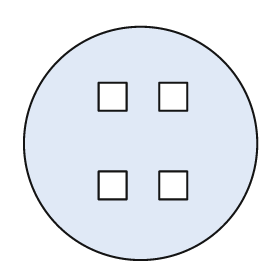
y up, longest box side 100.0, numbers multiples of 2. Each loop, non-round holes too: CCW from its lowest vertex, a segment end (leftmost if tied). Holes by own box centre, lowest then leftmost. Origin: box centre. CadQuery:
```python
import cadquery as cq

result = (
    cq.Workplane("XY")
    .moveTo(0.0, 0.0)
    .circle(50.0)
    .moveTo(-18.0, -24.0)
    .lineTo(-6.0, -24.0)
    .lineTo(-6.0, -12.0)
    .lineTo(-18.0, -12.0)
    .close()
    .moveTo(8.0, -24.0)
    .lineTo(20.0, -24.0)
    .lineTo(20.0, -12.0)
    .lineTo(8.0, -12.0)
    .close()
    .moveTo(-18.0, 14.0)
    .lineTo(-6.0, 14.0)
    .lineTo(-6.0, 26.0)
    .lineTo(-18.0, 26.0)
    .close()
    .moveTo(8.0, 14.0)
    .lineTo(20.0, 14.0)
    .lineTo(20.0, 26.0)
    .lineTo(8.0, 26.0)
    .close()
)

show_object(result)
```